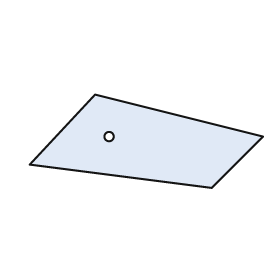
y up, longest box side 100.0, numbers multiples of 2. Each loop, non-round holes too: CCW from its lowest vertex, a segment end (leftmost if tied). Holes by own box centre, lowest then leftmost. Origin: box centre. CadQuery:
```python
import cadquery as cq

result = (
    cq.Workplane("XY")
    .moveTo(28.0, -20.0)
    .lineTo(50.0, 2.0)
    .lineTo(-22.0, 20.0)
    .lineTo(-50.0, -10.0)
    .close()
    .moveTo(-16.0, 2.0)
    .circle(2.0)
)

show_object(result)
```